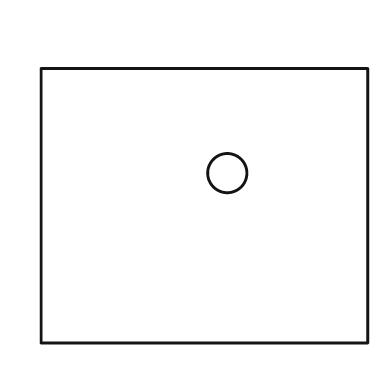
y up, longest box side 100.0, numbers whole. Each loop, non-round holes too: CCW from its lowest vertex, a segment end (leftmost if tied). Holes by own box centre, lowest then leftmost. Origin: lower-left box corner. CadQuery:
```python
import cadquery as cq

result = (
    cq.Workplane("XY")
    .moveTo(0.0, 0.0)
    .lineTo(100.0, 0.0)
    .lineTo(100.0, 84.0)
    .lineTo(0.0, 84.0)
    .close()
    .moveTo(57.0, 52.0)
    .circle(6.0)
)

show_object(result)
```